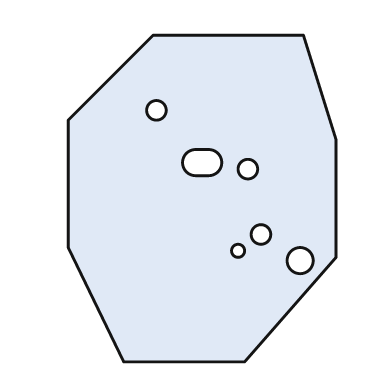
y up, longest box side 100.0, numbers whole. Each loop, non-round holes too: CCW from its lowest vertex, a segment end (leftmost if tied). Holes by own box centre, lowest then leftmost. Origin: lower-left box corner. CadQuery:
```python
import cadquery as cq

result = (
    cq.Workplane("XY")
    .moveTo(17.0, 0.0)
    .lineTo(54.0, 0.0)
    .lineTo(82.0, 32.0)
    .lineTo(82.0, 68.0)
    .lineTo(72.0, 100.0)
    .lineTo(26.0, 100.0)
    .lineTo(0.0, 74.0)
    .lineTo(0.0, 35.0)
    .close()
    .moveTo(71.0, 31.0)
    .circle(4.0)
    .moveTo(52.0, 34.0)
    .circle(2.0)
    .moveTo(59.0, 39.0)
    .circle(3.0)
    .moveTo(55.0, 59.0)
    .circle(3.0)
    .moveTo(39.0, 57.0)
    .lineTo(43.0, 57.0)
    .threePointArc((47.0, 61.0), (43.0, 65.0))
    .lineTo(39.0, 65.0)
    .threePointArc((35.0, 61.0), (39.0, 57.0))
    .close()
    .moveTo(27.0, 77.0)
    .circle(3.0)
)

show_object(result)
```